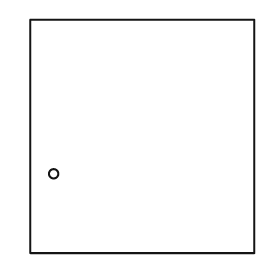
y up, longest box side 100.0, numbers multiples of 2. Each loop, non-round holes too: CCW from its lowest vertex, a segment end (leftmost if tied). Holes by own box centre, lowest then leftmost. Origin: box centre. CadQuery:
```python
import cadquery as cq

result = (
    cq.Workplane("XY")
    .moveTo(-48.0, -50.0)
    .lineTo(48.0, -50.0)
    .lineTo(48.0, 50.0)
    .lineTo(-48.0, 50.0)
    .close()
    .moveTo(-38.0, -16.0)
    .circle(2.0)
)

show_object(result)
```